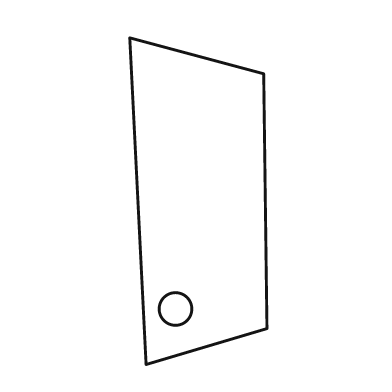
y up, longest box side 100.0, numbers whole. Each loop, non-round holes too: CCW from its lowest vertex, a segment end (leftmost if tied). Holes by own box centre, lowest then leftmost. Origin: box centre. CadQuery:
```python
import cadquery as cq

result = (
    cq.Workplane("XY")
    .moveTo(-16.0, -50.0)
    .lineTo(21.0, -39.0)
    .lineTo(20.0, 39.0)
    .lineTo(-21.0, 50.0)
    .close()
    .moveTo(-7.0, -33.0)
    .circle(5.0)
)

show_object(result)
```